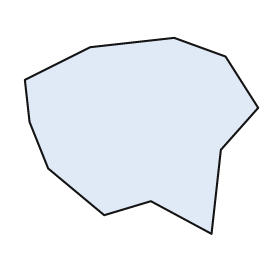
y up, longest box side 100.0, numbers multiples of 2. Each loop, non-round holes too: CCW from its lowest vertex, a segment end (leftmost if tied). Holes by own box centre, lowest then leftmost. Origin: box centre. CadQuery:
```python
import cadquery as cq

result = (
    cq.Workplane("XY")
    .moveTo(30.0, -42.0)
    .lineTo(34.0, -6.0)
    .lineTo(50.0, 12.0)
    .lineTo(36.0, 34.0)
    .lineTo(14.0, 42.0)
    .lineTo(-22.0, 38.0)
    .lineTo(-50.0, 24.0)
    .lineTo(-48.0, 6.0)
    .lineTo(-40.0, -14.0)
    .lineTo(-16.0, -34.0)
    .lineTo(4.0, -28.0)
    .close()
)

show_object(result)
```